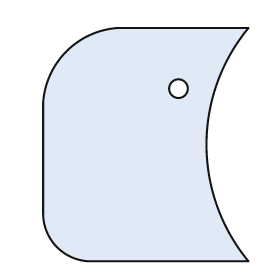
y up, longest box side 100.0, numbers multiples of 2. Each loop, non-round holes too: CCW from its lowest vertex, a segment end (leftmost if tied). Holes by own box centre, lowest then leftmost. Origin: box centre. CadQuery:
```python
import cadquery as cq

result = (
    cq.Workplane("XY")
    .moveTo(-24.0, -50.0)
    .lineTo(44.0, -50.0)
    .threePointArc((26.0, 0.0), (44.0, 50.0))
    .lineTo(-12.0, 50.0)
    .threePointArc((-34.0, 40.0), (-44.0, 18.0))
    .lineTo(-44.0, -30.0)
    .threePointArc((-38.0, -44.0), (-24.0, -50.0))
    .close()
    .moveTo(14.0, 24.0)
    .circle(4.0)
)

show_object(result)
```